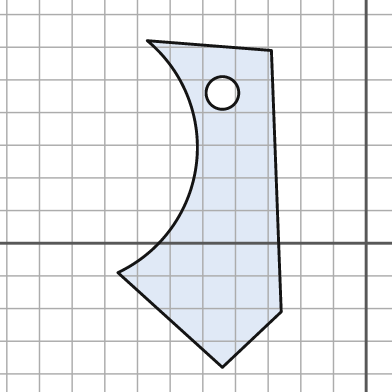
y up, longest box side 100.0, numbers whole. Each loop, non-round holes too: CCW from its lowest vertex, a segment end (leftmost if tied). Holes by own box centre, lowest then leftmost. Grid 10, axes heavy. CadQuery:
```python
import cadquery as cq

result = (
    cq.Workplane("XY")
    .moveTo(-44.0, -38.0)
    .lineTo(-26.0, -21.0)
    .lineTo(-29.0, 59.0)
    .lineTo(-67.0, 62.0)
    .threePointArc((-52.0, 24.0), (-76.0, -9.0))
    .close()
    .moveTo(-44.0, 46.0)
    .circle(5.0)
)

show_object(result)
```